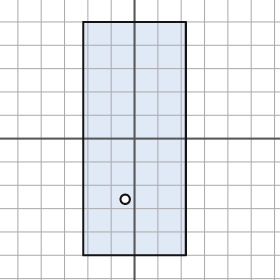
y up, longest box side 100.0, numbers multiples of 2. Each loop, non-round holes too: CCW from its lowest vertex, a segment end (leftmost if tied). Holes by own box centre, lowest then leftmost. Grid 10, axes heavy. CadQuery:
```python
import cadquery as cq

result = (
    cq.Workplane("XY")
    .moveTo(-22.0, -50.0)
    .lineTo(22.0, -50.0)
    .lineTo(22.0, 50.0)
    .lineTo(-22.0, 50.0)
    .close()
    .moveTo(-4.0, -26.0)
    .circle(2.0)
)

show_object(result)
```